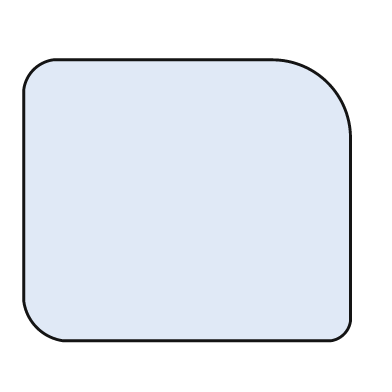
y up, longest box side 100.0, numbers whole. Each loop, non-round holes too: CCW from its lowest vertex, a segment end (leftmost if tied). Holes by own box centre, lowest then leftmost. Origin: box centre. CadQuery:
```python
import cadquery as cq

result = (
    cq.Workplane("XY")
    .moveTo(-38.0, -43.0)
    .lineTo(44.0, -43.0)
    .threePointArc((48.0, -41.0), (50.0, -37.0))
    .lineTo(50.0, 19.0)
    .threePointArc((43.0, 36.0), (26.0, 43.0))
    .lineTo(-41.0, 43.0)
    .threePointArc((-47.0, 40.0), (-50.0, 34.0))
    .lineTo(-50.0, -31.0)
    .threePointArc((-46.0, -39.0), (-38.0, -43.0))
    .close()
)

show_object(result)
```